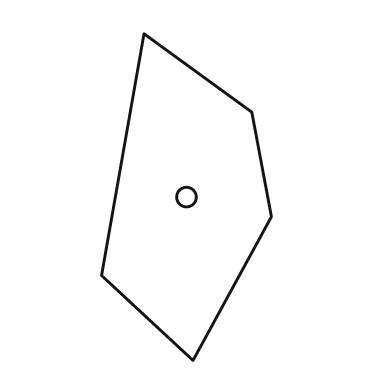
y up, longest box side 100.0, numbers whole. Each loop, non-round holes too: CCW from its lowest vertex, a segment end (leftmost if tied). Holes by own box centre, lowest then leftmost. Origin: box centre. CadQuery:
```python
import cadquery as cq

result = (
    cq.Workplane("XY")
    .moveTo(2.0, -50.0)
    .lineTo(26.0, -6.0)
    .lineTo(20.0, 26.0)
    .lineTo(-13.0, 50.0)
    .lineTo(-26.0, -24.0)
    .close()
    .moveTo(0.0, 0.0)
    .circle(3.0)
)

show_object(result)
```